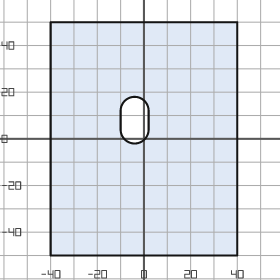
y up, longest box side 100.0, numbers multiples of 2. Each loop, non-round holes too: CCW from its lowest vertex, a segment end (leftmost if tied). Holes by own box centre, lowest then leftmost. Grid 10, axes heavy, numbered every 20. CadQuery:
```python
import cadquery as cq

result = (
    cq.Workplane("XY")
    .moveTo(-40.0, -50.0)
    .lineTo(40.0, -50.0)
    .lineTo(40.0, 50.0)
    .lineTo(-40.0, 50.0)
    .close()
    .moveTo(-10.0, 4.0)
    .threePointArc((-4.0, -2.0), (2.0, 4.0))
    .lineTo(2.0, 12.0)
    .threePointArc((-4.0, 18.0), (-10.0, 12.0))
    .close()
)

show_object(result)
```